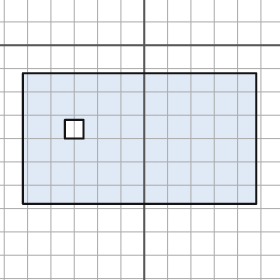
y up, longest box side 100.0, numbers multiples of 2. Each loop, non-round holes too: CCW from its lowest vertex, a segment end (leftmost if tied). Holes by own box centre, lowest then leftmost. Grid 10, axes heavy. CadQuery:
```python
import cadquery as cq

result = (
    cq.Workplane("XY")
    .moveTo(-52.0, -68.0)
    .lineTo(48.0, -68.0)
    .lineTo(48.0, -12.0)
    .lineTo(-52.0, -12.0)
    .close()
    .moveTo(-34.0, -40.0)
    .lineTo(-26.0, -40.0)
    .lineTo(-26.0, -32.0)
    .lineTo(-34.0, -32.0)
    .close()
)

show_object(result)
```